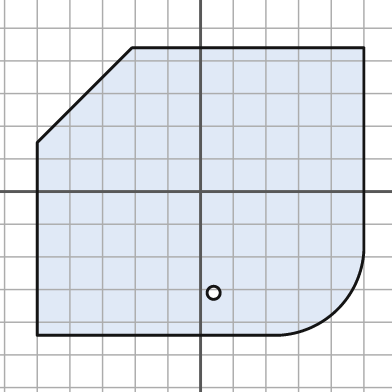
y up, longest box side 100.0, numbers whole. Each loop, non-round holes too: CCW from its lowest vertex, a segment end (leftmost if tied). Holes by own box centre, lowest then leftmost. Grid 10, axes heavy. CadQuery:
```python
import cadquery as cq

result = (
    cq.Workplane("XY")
    .moveTo(-50.0, -44.0)
    .lineTo(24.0, -44.0)
    .threePointArc((42.0, -36.0), (50.0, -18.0))
    .lineTo(50.0, 44.0)
    .lineTo(-21.0, 44.0)
    .lineTo(-50.0, 15.0)
    .close()
    .moveTo(4.0, -31.0)
    .circle(2.0)
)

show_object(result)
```